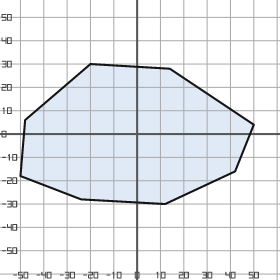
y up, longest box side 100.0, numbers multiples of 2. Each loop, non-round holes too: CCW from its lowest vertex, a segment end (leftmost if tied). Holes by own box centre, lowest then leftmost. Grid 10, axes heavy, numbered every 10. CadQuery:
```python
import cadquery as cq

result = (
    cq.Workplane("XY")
    .moveTo(12.0, -30.0)
    .lineTo(42.0, -16.0)
    .lineTo(50.0, 4.0)
    .lineTo(14.0, 28.0)
    .lineTo(-20.0, 30.0)
    .lineTo(-48.0, 6.0)
    .lineTo(-50.0, -18.0)
    .lineTo(-24.0, -28.0)
    .close()
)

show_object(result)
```